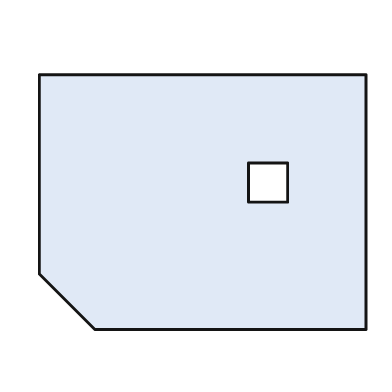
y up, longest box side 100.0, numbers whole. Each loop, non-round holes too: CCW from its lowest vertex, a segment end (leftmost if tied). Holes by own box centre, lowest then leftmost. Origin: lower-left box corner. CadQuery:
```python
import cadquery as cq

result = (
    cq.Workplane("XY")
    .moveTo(17.0, 0.0)
    .lineTo(100.0, 0.0)
    .lineTo(100.0, 78.0)
    .lineTo(0.0, 78.0)
    .lineTo(0.0, 17.0)
    .close()
    .moveTo(64.0, 39.0)
    .lineTo(76.0, 39.0)
    .lineTo(76.0, 51.0)
    .lineTo(64.0, 51.0)
    .close()
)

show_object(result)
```